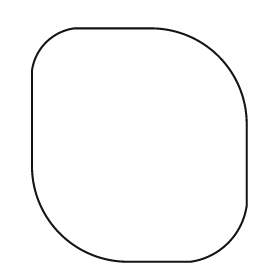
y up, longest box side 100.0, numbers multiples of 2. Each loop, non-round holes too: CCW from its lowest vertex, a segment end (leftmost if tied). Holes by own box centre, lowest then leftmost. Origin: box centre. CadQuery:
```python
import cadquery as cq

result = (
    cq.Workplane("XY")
    .moveTo(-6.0, -50.0)
    .lineTo(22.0, -50.0)
    .threePointArc((38.0, -42.0), (46.0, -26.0))
    .lineTo(46.0, 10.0)
    .threePointArc((34.0, 38.0), (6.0, 50.0))
    .lineTo(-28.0, 50.0)
    .threePointArc((-40.0, 44.0), (-46.0, 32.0))
    .lineTo(-46.0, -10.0)
    .threePointArc((-34.0, -38.0), (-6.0, -50.0))
    .close()
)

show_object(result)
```